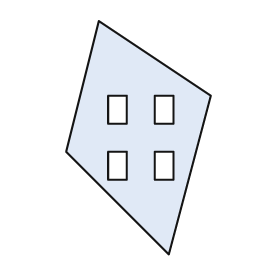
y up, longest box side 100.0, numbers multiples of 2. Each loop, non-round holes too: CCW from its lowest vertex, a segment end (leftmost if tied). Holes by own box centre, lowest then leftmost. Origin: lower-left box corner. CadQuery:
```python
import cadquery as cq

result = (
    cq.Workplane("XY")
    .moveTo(44.0, 0.0)
    .lineTo(62.0, 68.0)
    .lineTo(14.0, 100.0)
    .lineTo(0.0, 44.0)
    .close()
    .moveTo(18.0, 32.0)
    .lineTo(26.0, 32.0)
    .lineTo(26.0, 44.0)
    .lineTo(18.0, 44.0)
    .close()
    .moveTo(38.0, 32.0)
    .lineTo(46.0, 32.0)
    .lineTo(46.0, 44.0)
    .lineTo(38.0, 44.0)
    .close()
    .moveTo(18.0, 56.0)
    .lineTo(26.0, 56.0)
    .lineTo(26.0, 68.0)
    .lineTo(18.0, 68.0)
    .close()
    .moveTo(38.0, 56.0)
    .lineTo(46.0, 56.0)
    .lineTo(46.0, 68.0)
    .lineTo(38.0, 68.0)
    .close()
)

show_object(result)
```